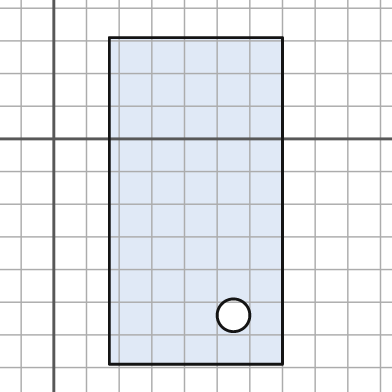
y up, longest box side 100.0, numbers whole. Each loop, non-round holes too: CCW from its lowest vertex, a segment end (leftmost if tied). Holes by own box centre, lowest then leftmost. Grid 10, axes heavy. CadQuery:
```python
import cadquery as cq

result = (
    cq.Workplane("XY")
    .moveTo(17.0, -69.0)
    .lineTo(70.0, -69.0)
    .lineTo(70.0, 31.0)
    .lineTo(17.0, 31.0)
    .close()
    .moveTo(55.0, -54.0)
    .circle(5.0)
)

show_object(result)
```